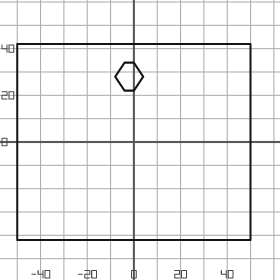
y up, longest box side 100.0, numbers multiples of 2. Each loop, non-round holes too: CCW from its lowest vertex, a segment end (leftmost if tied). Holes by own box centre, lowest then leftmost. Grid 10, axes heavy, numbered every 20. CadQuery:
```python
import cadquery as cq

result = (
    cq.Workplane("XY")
    .moveTo(-50.0, -42.0)
    .lineTo(50.0, -42.0)
    .lineTo(50.0, 42.0)
    .lineTo(-50.0, 42.0)
    .close()
    .moveTo(-4.0, 22.0)
    .lineTo(0.0, 22.0)
    .lineTo(4.0, 28.0)
    .lineTo(0.0, 34.0)
    .lineTo(-4.0, 34.0)
    .lineTo(-8.0, 28.0)
    .close()
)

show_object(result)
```